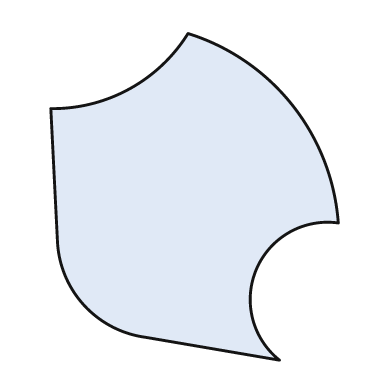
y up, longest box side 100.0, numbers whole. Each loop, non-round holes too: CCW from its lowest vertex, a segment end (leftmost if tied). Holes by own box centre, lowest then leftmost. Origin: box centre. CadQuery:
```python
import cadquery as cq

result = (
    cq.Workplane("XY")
    .moveTo(26.0, -50.0)
    .threePointArc((19.0, -22.0), (44.0, -8.0))
    .threePointArc((30.0, 28.0), (-2.0, 50.0))
    .threePointArc((-20.0, 33.0), (-44.0, 27.0))
    .lineTo(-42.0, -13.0)
    .threePointArc((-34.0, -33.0), (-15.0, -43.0))
    .close()
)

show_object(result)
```